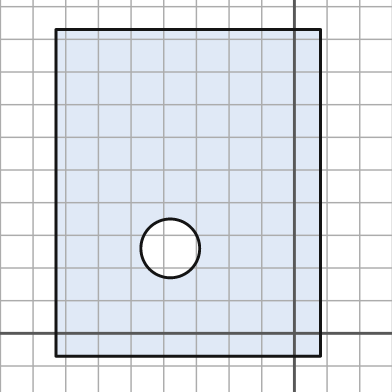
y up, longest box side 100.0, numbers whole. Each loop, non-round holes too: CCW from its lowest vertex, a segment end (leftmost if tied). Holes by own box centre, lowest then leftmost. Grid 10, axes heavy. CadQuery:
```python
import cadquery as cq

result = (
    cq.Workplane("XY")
    .moveTo(-73.0, -7.0)
    .lineTo(8.0, -7.0)
    .lineTo(8.0, 93.0)
    .lineTo(-73.0, 93.0)
    .close()
    .moveTo(-38.0, 26.0)
    .circle(9.0)
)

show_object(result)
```